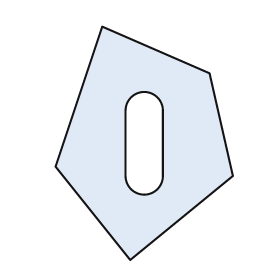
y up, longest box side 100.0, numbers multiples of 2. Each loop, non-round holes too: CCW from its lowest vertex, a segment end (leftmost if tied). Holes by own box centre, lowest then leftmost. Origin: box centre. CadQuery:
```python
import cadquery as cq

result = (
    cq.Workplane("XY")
    .moveTo(-6.0, -50.0)
    .lineTo(38.0, -14.0)
    .lineTo(28.0, 30.0)
    .lineTo(-18.0, 50.0)
    .lineTo(-38.0, -10.0)
    .close()
    .moveTo(-8.0, -14.0)
    .threePointArc((0.0, -22.0), (8.0, -14.0))
    .lineTo(8.0, 14.0)
    .threePointArc((0.0, 22.0), (-8.0, 14.0))
    .close()
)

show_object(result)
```